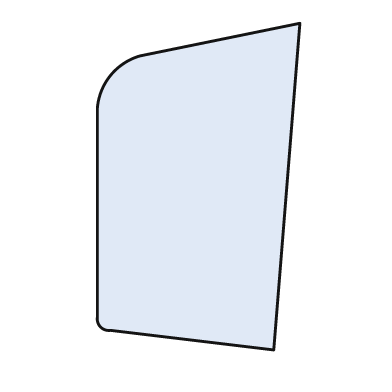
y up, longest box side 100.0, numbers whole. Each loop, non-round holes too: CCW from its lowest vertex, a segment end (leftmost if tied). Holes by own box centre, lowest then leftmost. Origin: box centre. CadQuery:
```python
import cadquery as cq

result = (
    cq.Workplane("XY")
    .moveTo(23.0, -50.0)
    .lineTo(31.0, 50.0)
    .lineTo(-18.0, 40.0)
    .threePointArc((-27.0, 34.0), (-31.0, 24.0))
    .lineTo(-31.0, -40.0)
    .threePointArc((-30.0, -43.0), (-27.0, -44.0))
    .close()
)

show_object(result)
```